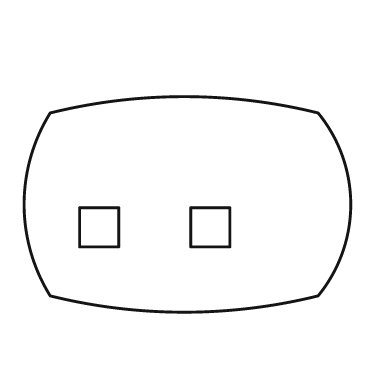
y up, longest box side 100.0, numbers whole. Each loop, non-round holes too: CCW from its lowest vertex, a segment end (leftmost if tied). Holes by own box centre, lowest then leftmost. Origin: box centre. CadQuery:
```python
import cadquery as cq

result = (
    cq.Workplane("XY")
    .moveTo(-42.0, -28.0)
    .threePointArc((-1.0, -33.0), (40.0, -28.0))
    .threePointArc((50.0, 0.0), (40.0, 28.0))
    .threePointArc((-1.0, 33.0), (-42.0, 28.0))
    .threePointArc((-50.0, 0.0), (-42.0, -28.0))
    .close()
    .moveTo(-33.0, -13.0)
    .lineTo(-21.0, -13.0)
    .lineTo(-21.0, -1.0)
    .lineTo(-33.0, -1.0)
    .close()
    .moveTo(1.0, -13.0)
    .lineTo(13.0, -13.0)
    .lineTo(13.0, -1.0)
    .lineTo(1.0, -1.0)
    .close()
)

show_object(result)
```